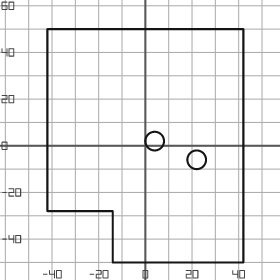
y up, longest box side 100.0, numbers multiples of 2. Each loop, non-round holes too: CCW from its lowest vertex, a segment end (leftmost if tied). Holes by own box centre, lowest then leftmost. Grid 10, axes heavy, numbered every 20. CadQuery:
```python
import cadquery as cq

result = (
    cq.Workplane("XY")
    .moveTo(-14.0, -50.0)
    .lineTo(42.0, -50.0)
    .lineTo(42.0, 50.0)
    .lineTo(-42.0, 50.0)
    .lineTo(-42.0, -28.0)
    .lineTo(-14.0, -28.0)
    .close()
    .moveTo(22.0, -6.0)
    .circle(4.0)
    .moveTo(4.0, 2.0)
    .circle(4.0)
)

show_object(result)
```